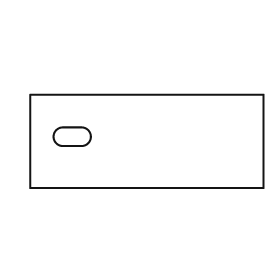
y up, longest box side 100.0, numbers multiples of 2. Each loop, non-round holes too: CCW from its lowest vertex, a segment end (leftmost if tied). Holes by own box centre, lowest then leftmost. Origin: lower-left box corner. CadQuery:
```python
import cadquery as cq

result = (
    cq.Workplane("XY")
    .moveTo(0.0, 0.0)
    .lineTo(100.0, 0.0)
    .lineTo(100.0, 40.0)
    .lineTo(0.0, 40.0)
    .close()
    .moveTo(14.0, 18.0)
    .lineTo(22.0, 18.0)
    .threePointArc((26.0, 22.0), (22.0, 26.0))
    .lineTo(14.0, 26.0)
    .threePointArc((10.0, 22.0), (14.0, 18.0))
    .close()
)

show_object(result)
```